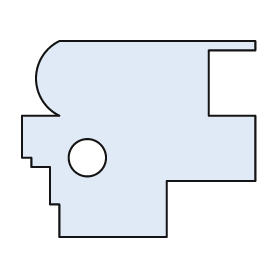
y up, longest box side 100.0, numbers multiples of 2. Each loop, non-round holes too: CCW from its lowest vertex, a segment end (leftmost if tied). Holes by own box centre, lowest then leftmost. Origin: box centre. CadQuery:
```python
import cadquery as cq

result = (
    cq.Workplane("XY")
    .moveTo(-34.0, -42.0)
    .lineTo(12.0, -42.0)
    .lineTo(12.0, -18.0)
    .lineTo(50.0, -18.0)
    .lineTo(50.0, 10.0)
    .lineTo(30.0, 10.0)
    .lineTo(30.0, 38.0)
    .lineTo(50.0, 38.0)
    .lineTo(50.0, 42.0)
    .lineTo(-34.0, 42.0)
    .threePointArc((-44.0, 26.0), (-34.0, 10.0))
    .lineTo(-50.0, 10.0)
    .lineTo(-50.0, -8.0)
    .lineTo(-46.0, -8.0)
    .lineTo(-46.0, -12.0)
    .lineTo(-38.0, -12.0)
    .lineTo(-38.0, -28.0)
    .lineTo(-34.0, -28.0)
    .close()
    .moveTo(-22.0, -8.0)
    .circle(8.0)
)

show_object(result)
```